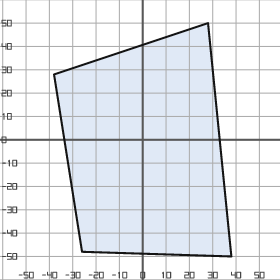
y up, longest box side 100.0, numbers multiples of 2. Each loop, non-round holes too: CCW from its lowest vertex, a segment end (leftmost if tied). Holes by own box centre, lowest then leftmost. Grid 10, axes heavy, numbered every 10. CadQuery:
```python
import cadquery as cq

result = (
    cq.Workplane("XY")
    .moveTo(38.0, -50.0)
    .lineTo(28.0, 50.0)
    .lineTo(-38.0, 28.0)
    .lineTo(-26.0, -48.0)
    .close()
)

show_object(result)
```